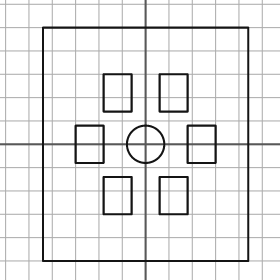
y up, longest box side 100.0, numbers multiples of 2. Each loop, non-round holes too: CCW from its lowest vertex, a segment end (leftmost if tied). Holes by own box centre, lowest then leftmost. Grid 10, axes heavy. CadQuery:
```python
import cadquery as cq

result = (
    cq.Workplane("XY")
    .moveTo(-44.0, -50.0)
    .lineTo(44.0, -50.0)
    .lineTo(44.0, 50.0)
    .lineTo(-44.0, 50.0)
    .close()
    .moveTo(-18.0, -30.0)
    .lineTo(-6.0, -30.0)
    .lineTo(-6.0, -14.0)
    .lineTo(-18.0, -14.0)
    .close()
    .moveTo(6.0, -30.0)
    .lineTo(18.0, -30.0)
    .lineTo(18.0, -14.0)
    .lineTo(6.0, -14.0)
    .close()
    .moveTo(-30.0, -8.0)
    .lineTo(-18.0, -8.0)
    .lineTo(-18.0, 8.0)
    .lineTo(-30.0, 8.0)
    .close()
    .moveTo(0.0, 0.0)
    .circle(8.0)
    .moveTo(18.0, -8.0)
    .lineTo(30.0, -8.0)
    .lineTo(30.0, 8.0)
    .lineTo(18.0, 8.0)
    .close()
    .moveTo(-18.0, 14.0)
    .lineTo(-6.0, 14.0)
    .lineTo(-6.0, 30.0)
    .lineTo(-18.0, 30.0)
    .close()
    .moveTo(6.0, 14.0)
    .lineTo(18.0, 14.0)
    .lineTo(18.0, 30.0)
    .lineTo(6.0, 30.0)
    .close()
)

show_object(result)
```